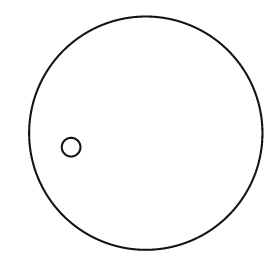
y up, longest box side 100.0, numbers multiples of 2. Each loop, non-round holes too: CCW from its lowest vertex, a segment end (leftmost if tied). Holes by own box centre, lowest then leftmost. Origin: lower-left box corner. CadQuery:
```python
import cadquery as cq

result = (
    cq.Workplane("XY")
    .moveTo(50.0, 50.0)
    .circle(50.0)
    .moveTo(18.0, 44.0)
    .circle(4.0)
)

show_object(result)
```